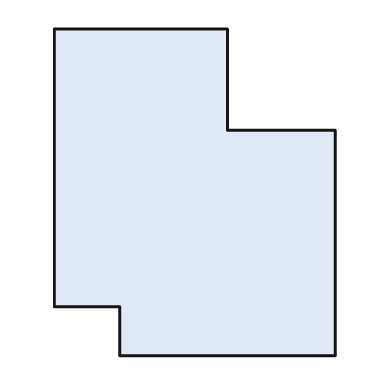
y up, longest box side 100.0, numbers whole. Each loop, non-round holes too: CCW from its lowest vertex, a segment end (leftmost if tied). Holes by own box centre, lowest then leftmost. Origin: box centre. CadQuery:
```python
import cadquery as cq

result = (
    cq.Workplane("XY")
    .moveTo(-23.0, -50.0)
    .lineTo(43.0, -50.0)
    .lineTo(43.0, 19.0)
    .lineTo(10.0, 19.0)
    .lineTo(10.0, 50.0)
    .lineTo(-43.0, 50.0)
    .lineTo(-43.0, -35.0)
    .lineTo(-23.0, -35.0)
    .close()
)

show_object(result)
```